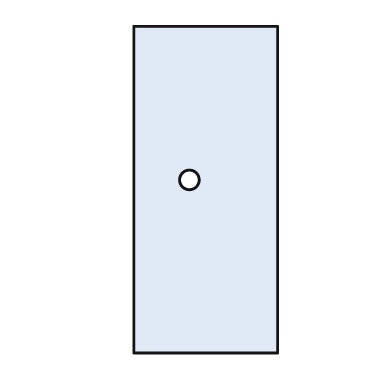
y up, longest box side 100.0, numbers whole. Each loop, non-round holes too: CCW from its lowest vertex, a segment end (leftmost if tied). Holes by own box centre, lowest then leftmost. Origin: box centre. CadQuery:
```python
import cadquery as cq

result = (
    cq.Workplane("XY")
    .moveTo(-22.0, -50.0)
    .lineTo(22.0, -50.0)
    .lineTo(22.0, 50.0)
    .lineTo(-22.0, 50.0)
    .close()
    .moveTo(-5.0, 3.0)
    .circle(3.0)
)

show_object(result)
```